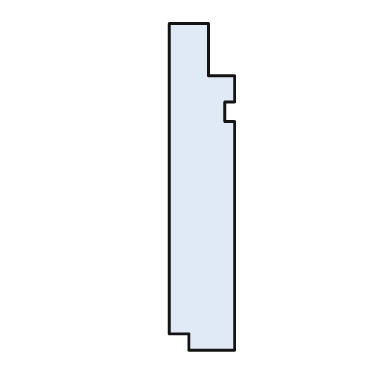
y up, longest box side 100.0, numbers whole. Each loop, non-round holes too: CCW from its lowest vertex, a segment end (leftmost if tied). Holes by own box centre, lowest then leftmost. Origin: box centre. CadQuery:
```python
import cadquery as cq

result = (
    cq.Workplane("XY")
    .moveTo(-4.0, -50.0)
    .lineTo(10.0, -50.0)
    .lineTo(10.0, 20.0)
    .lineTo(7.0, 20.0)
    .lineTo(7.0, 26.0)
    .lineTo(10.0, 26.0)
    .lineTo(10.0, 34.0)
    .lineTo(2.0, 34.0)
    .lineTo(2.0, 50.0)
    .lineTo(-10.0, 50.0)
    .lineTo(-10.0, -45.0)
    .lineTo(-4.0, -45.0)
    .close()
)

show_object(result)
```